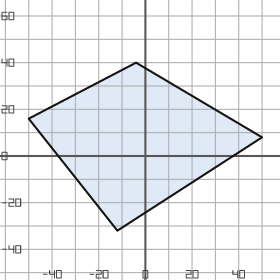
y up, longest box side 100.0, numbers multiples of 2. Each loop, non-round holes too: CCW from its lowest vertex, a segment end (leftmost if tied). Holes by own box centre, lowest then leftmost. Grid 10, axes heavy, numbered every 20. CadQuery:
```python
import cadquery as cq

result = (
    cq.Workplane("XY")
    .moveTo(-12.0, -32.0)
    .lineTo(50.0, 8.0)
    .lineTo(-4.0, 40.0)
    .lineTo(-50.0, 16.0)
    .close()
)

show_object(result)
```